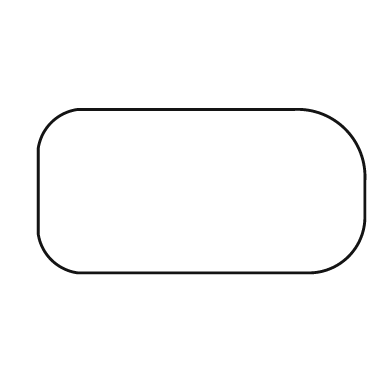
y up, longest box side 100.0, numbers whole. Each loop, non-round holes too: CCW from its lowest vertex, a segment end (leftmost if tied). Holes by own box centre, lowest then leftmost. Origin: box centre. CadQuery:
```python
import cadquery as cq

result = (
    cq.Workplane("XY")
    .moveTo(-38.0, -25.0)
    .lineTo(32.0, -25.0)
    .threePointArc((45.0, -20.0), (50.0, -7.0))
    .lineTo(50.0, 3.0)
    .threePointArc((44.0, 19.0), (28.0, 25.0))
    .lineTo(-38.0, 25.0)
    .threePointArc((-46.0, 21.0), (-50.0, 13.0))
    .lineTo(-50.0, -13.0)
    .threePointArc((-46.0, -21.0), (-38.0, -25.0))
    .close()
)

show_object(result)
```